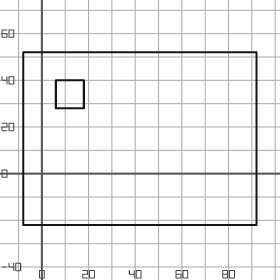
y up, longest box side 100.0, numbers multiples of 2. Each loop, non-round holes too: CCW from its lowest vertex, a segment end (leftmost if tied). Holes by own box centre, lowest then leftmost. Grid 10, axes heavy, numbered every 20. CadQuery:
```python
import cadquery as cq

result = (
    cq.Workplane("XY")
    .moveTo(-8.0, -22.0)
    .lineTo(92.0, -22.0)
    .lineTo(92.0, 52.0)
    .lineTo(-8.0, 52.0)
    .close()
    .moveTo(6.0, 28.0)
    .lineTo(18.0, 28.0)
    .lineTo(18.0, 40.0)
    .lineTo(6.0, 40.0)
    .close()
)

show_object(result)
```